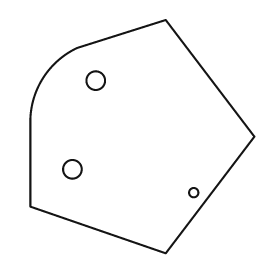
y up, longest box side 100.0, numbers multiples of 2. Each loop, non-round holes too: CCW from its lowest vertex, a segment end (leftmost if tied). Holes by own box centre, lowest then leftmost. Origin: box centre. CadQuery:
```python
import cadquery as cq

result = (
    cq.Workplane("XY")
    .moveTo(10.0, -50.0)
    .lineTo(48.0, 0.0)
    .lineTo(10.0, 50.0)
    .lineTo(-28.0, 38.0)
    .threePointArc((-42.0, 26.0), (-48.0, 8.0))
    .lineTo(-48.0, -30.0)
    .close()
    .moveTo(22.0, -24.0)
    .circle(2.0)
    .moveTo(-30.0, -14.0)
    .circle(4.0)
    .moveTo(-20.0, 24.0)
    .circle(4.0)
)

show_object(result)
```